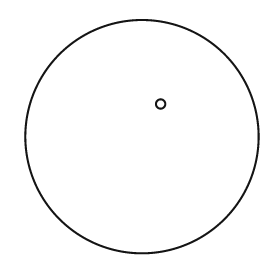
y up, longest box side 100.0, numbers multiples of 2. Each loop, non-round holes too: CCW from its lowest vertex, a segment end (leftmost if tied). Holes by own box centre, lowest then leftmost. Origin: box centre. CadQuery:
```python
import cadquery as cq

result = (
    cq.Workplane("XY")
    .moveTo(0.0, 0.0)
    .circle(50.0)
    .moveTo(8.0, 14.0)
    .circle(2.0)
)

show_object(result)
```